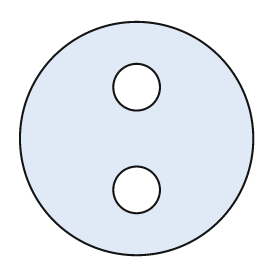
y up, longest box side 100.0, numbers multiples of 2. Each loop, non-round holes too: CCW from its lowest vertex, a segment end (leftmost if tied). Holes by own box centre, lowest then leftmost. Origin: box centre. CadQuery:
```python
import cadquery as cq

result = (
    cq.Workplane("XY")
    .moveTo(0.0, 0.0)
    .circle(50.0)
    .moveTo(0.0, -22.0)
    .circle(10.0)
    .moveTo(0.0, 22.0)
    .circle(10.0)
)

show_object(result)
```